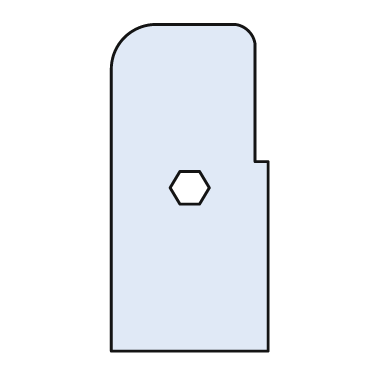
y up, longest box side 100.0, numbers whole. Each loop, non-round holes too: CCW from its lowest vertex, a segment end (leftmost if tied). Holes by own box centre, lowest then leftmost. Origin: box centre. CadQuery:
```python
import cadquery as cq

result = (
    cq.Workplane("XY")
    .moveTo(-24.0, -50.0)
    .lineTo(24.0, -50.0)
    .lineTo(24.0, 8.0)
    .lineTo(20.0, 8.0)
    .lineTo(20.0, 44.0)
    .threePointArc((18.0, 48.0), (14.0, 50.0))
    .lineTo(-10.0, 50.0)
    .threePointArc((-20.0, 46.0), (-24.0, 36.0))
    .close()
    .moveTo(-3.0, -5.0)
    .lineTo(3.0, -5.0)
    .lineTo(6.0, 0.0)
    .lineTo(3.0, 5.0)
    .lineTo(-3.0, 5.0)
    .lineTo(-6.0, 0.0)
    .close()
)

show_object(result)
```